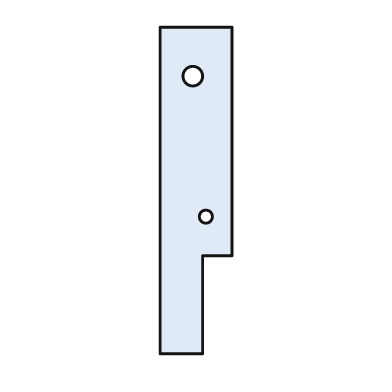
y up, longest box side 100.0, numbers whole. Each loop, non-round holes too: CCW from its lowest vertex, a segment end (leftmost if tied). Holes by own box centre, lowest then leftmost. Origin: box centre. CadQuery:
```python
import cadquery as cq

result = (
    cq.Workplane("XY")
    .moveTo(-11.0, -50.0)
    .lineTo(2.0, -50.0)
    .lineTo(2.0, -20.0)
    .lineTo(11.0, -20.0)
    .lineTo(11.0, 50.0)
    .lineTo(-11.0, 50.0)
    .close()
    .moveTo(3.0, -8.0)
    .circle(2.0)
    .moveTo(-1.0, 35.0)
    .circle(3.0)
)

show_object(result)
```